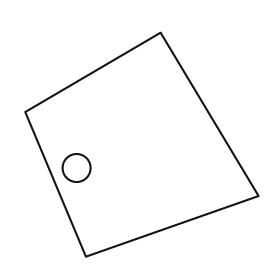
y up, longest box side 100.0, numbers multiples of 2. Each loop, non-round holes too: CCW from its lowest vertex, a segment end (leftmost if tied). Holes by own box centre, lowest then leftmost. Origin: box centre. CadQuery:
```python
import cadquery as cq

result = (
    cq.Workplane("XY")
    .moveTo(-24.0, -48.0)
    .lineTo(50.0, -22.0)
    .lineTo(8.0, 48.0)
    .lineTo(-50.0, 14.0)
    .close()
    .moveTo(-28.0, -10.0)
    .circle(6.0)
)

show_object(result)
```